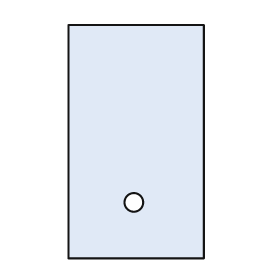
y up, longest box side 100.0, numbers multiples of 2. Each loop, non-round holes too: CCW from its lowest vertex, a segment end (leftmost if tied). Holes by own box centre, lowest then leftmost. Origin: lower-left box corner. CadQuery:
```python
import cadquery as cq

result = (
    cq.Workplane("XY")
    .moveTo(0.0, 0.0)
    .lineTo(58.0, 0.0)
    .lineTo(58.0, 100.0)
    .lineTo(0.0, 100.0)
    .close()
    .moveTo(28.0, 24.0)
    .circle(4.0)
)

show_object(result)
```